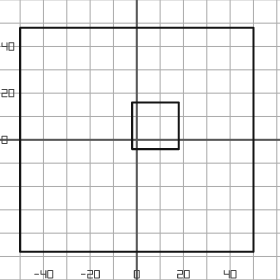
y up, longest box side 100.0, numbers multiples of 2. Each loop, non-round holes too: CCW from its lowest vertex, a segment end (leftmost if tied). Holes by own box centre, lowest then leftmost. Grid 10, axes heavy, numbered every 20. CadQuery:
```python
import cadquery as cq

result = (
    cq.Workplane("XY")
    .moveTo(-50.0, -48.0)
    .lineTo(50.0, -48.0)
    .lineTo(50.0, 48.0)
    .lineTo(-50.0, 48.0)
    .close()
    .moveTo(-2.0, -4.0)
    .lineTo(18.0, -4.0)
    .lineTo(18.0, 16.0)
    .lineTo(-2.0, 16.0)
    .close()
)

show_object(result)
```